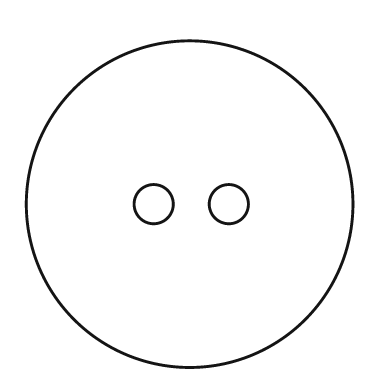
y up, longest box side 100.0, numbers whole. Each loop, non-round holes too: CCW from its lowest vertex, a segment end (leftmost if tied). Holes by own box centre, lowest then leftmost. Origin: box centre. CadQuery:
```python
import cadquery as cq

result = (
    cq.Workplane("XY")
    .moveTo(0.0, 0.0)
    .circle(50.0)
    .moveTo(-11.0, 0.0)
    .circle(6.0)
    .moveTo(12.0, 0.0)
    .circle(6.0)
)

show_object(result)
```